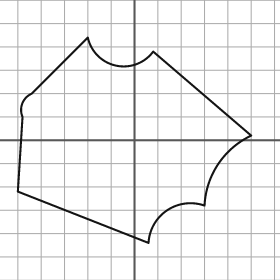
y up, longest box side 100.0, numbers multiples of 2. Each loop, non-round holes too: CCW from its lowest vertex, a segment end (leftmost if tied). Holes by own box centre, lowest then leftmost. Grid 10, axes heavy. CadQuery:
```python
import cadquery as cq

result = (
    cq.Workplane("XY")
    .moveTo(6.0, -44.0)
    .threePointArc((14.0, -30.0), (30.0, -28.0))
    .threePointArc((36.0, -10.0), (50.0, 2.0))
    .lineTo(8.0, 38.0)
    .threePointArc((-8.0, 32.0), (-20.0, 44.0))
    .lineTo(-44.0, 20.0)
    .threePointArc((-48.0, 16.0), (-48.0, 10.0))
    .lineTo(-50.0, -22.0)
    .close()
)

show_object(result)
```